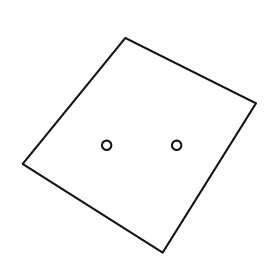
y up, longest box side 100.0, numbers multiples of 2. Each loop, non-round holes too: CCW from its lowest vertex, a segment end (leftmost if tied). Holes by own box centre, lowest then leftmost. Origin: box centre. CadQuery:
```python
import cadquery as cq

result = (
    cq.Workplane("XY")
    .moveTo(10.0, -46.0)
    .lineTo(50.0, 18.0)
    .lineTo(-6.0, 46.0)
    .lineTo(-50.0, -8.0)
    .close()
    .moveTo(-14.0, 0.0)
    .circle(2.0)
    .moveTo(16.0, 0.0)
    .circle(2.0)
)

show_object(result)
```